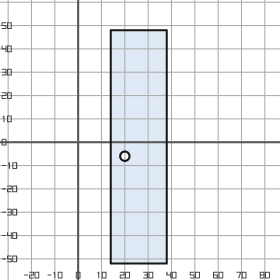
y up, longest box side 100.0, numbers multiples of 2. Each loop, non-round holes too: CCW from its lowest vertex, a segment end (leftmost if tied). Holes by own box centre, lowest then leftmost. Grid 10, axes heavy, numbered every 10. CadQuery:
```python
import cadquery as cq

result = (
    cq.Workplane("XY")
    .moveTo(14.0, -52.0)
    .lineTo(38.0, -52.0)
    .lineTo(38.0, 48.0)
    .lineTo(14.0, 48.0)
    .close()
    .moveTo(20.0, -6.0)
    .circle(2.0)
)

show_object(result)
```